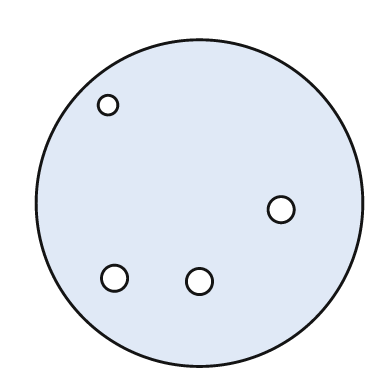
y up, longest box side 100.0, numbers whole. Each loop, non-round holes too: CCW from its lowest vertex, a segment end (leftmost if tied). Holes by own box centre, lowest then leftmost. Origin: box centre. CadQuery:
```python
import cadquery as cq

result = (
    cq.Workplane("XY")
    .moveTo(0.0, 0.0)
    .circle(50.0)
    .moveTo(0.0, -24.0)
    .circle(4.0)
    .moveTo(-26.0, -23.0)
    .circle(4.0)
    .moveTo(25.0, -2.0)
    .circle(4.0)
    .moveTo(-28.0, 30.0)
    .circle(3.0)
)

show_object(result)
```